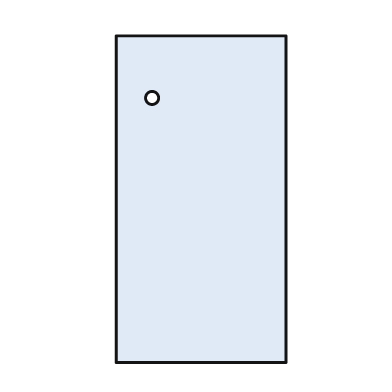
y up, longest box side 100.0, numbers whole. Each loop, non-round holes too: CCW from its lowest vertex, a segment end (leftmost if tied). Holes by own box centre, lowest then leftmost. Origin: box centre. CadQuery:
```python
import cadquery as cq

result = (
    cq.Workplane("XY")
    .moveTo(-26.0, -50.0)
    .lineTo(26.0, -50.0)
    .lineTo(26.0, 50.0)
    .lineTo(-26.0, 50.0)
    .close()
    .moveTo(-15.0, 31.0)
    .circle(2.0)
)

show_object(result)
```